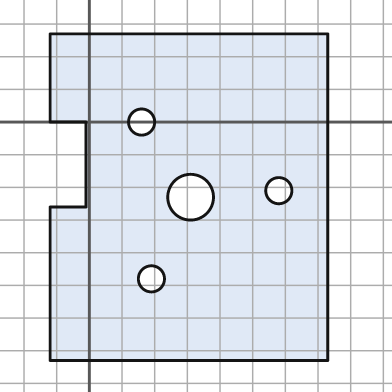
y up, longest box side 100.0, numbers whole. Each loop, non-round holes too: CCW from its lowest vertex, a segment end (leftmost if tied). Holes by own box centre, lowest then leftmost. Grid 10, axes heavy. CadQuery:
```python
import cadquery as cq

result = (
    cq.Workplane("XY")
    .moveTo(-12.0, -73.0)
    .lineTo(73.0, -73.0)
    .lineTo(73.0, 27.0)
    .lineTo(-12.0, 27.0)
    .lineTo(-12.0, 0.0)
    .lineTo(-1.0, 0.0)
    .lineTo(-1.0, -26.0)
    .lineTo(-12.0, -26.0)
    .close()
    .moveTo(19.0, -48.0)
    .circle(4.0)
    .moveTo(31.0, -23.0)
    .circle(7.0)
    .moveTo(58.0, -21.0)
    .circle(4.0)
    .moveTo(16.0, 0.0)
    .circle(4.0)
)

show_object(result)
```